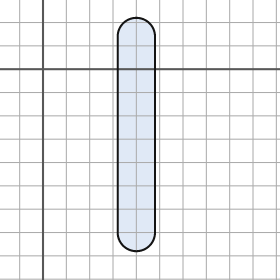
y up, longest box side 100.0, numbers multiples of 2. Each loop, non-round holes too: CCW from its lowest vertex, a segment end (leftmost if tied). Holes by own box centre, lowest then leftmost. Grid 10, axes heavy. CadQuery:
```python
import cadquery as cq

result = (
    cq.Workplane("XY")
    .moveTo(32.0, -70.0)
    .threePointArc((40.0, -78.0), (48.0, -70.0))
    .lineTo(48.0, 14.0)
    .threePointArc((40.0, 22.0), (32.0, 14.0))
    .close()
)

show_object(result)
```